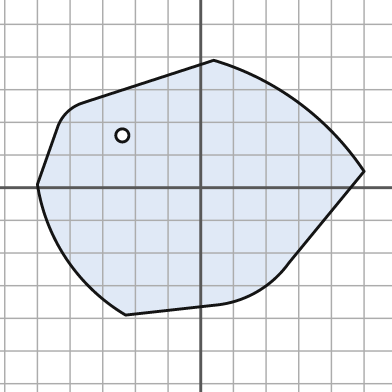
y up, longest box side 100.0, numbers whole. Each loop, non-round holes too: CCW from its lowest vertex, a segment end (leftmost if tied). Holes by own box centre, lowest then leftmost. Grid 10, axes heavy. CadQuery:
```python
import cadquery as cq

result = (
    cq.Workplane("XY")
    .moveTo(-23.0, -39.0)
    .lineTo(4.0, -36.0)
    .threePointArc((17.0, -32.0), (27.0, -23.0))
    .lineTo(50.0, 5.0)
    .threePointArc((30.0, 26.0), (4.0, 39.0))
    .lineTo(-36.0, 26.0)
    .threePointArc((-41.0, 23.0), (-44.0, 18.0))
    .lineTo(-50.0, 1.0)
    .threePointArc((-41.0, -22.0), (-23.0, -39.0))
    .close()
    .moveTo(-24.0, 16.0)
    .circle(2.0)
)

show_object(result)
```